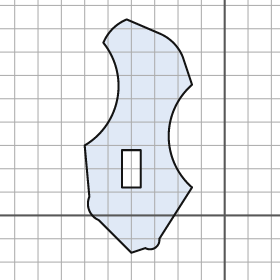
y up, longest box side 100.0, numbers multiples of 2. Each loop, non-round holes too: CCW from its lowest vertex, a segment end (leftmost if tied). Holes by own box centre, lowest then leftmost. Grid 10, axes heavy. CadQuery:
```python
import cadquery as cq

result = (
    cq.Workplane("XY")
    .moveTo(-40.0, -16.0)
    .lineTo(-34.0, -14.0)
    .threePointArc((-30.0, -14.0), (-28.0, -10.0))
    .lineTo(-14.0, 12.0)
    .threePointArc((-24.0, 34.0), (-14.0, 56.0))
    .lineTo(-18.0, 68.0)
    .threePointArc((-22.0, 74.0), (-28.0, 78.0))
    .lineTo(-42.0, 84.0)
    .threePointArc((-48.0, 80.0), (-52.0, 74.0))
    .threePointArc((-46.0, 50.0), (-60.0, 30.0))
    .lineTo(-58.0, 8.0)
    .threePointArc((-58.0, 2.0), (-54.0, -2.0))
    .close()
    .moveTo(-44.0, 12.0)
    .lineTo(-36.0, 12.0)
    .lineTo(-36.0, 28.0)
    .lineTo(-44.0, 28.0)
    .close()
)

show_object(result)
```